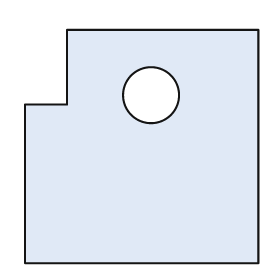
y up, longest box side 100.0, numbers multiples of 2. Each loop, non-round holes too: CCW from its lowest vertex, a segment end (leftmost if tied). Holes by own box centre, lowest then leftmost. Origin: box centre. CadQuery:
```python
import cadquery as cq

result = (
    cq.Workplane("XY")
    .moveTo(-50.0, -50.0)
    .lineTo(50.0, -50.0)
    .lineTo(50.0, 50.0)
    .lineTo(-32.0, 50.0)
    .lineTo(-32.0, 18.0)
    .lineTo(-50.0, 18.0)
    .close()
    .moveTo(4.0, 22.0)
    .circle(12.0)
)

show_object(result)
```